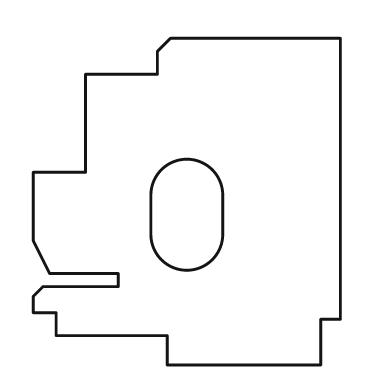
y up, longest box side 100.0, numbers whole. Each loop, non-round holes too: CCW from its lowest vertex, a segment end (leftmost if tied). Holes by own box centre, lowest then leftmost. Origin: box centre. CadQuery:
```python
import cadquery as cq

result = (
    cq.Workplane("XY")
    .moveTo(-6.0, -50.0)
    .lineTo(41.0, -50.0)
    .lineTo(41.0, -36.0)
    .lineTo(47.0, -36.0)
    .lineTo(47.0, 50.0)
    .lineTo(-5.0, 50.0)
    .lineTo(-9.0, 46.0)
    .lineTo(-9.0, 39.0)
    .lineTo(-31.0, 39.0)
    .lineTo(-31.0, 9.0)
    .lineTo(-47.0, 9.0)
    .lineTo(-47.0, -12.0)
    .lineTo(-42.0, -22.0)
    .lineTo(-21.0, -22.0)
    .lineTo(-21.0, -26.0)
    .lineTo(-44.0, -26.0)
    .lineTo(-47.0, -29.0)
    .lineTo(-47.0, -34.0)
    .lineTo(-40.0, -34.0)
    .lineTo(-40.0, -41.0)
    .lineTo(-6.0, -41.0)
    .close()
    .moveTo(-11.0, -10.0)
    .threePointArc((0.0, -21.0), (11.0, -10.0))
    .lineTo(11.0, 2.0)
    .threePointArc((0.0, 13.0), (-11.0, 2.0))
    .close()
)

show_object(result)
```